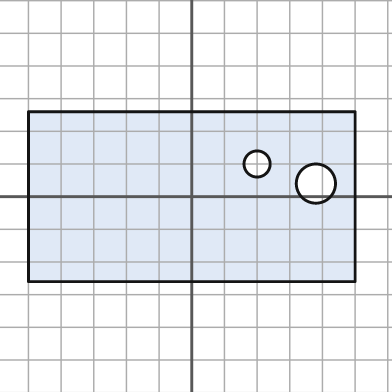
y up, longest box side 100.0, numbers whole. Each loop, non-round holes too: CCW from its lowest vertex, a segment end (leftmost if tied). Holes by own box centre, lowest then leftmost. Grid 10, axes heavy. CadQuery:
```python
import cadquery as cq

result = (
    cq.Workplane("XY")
    .moveTo(-50.0, -26.0)
    .lineTo(50.0, -26.0)
    .lineTo(50.0, 26.0)
    .lineTo(-50.0, 26.0)
    .close()
    .moveTo(38.0, 4.0)
    .circle(6.0)
    .moveTo(20.0, 10.0)
    .circle(4.0)
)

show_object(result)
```